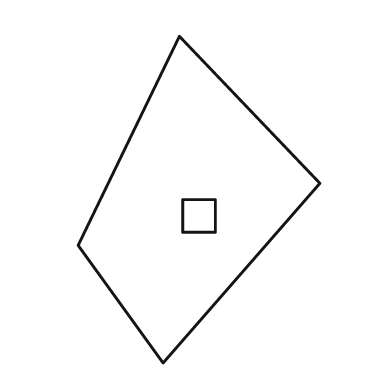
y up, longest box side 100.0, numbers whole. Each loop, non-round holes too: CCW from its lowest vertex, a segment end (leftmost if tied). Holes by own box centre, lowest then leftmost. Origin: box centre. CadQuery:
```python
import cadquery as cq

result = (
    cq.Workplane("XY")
    .moveTo(-11.0, -50.0)
    .lineTo(37.0, 5.0)
    .lineTo(-6.0, 50.0)
    .lineTo(-37.0, -14.0)
    .close()
    .moveTo(-5.0, -10.0)
    .lineTo(5.0, -10.0)
    .lineTo(5.0, 0.0)
    .lineTo(-5.0, 0.0)
    .close()
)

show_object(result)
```